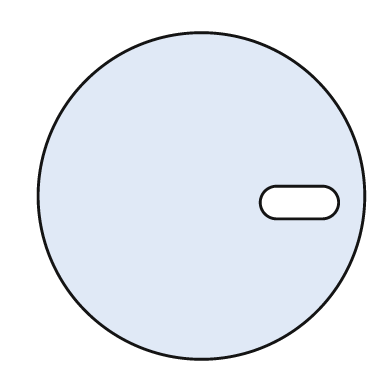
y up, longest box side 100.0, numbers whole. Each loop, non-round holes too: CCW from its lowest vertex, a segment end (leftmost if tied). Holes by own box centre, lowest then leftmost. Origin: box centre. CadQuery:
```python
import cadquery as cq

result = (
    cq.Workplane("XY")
    .moveTo(0.0, 0.0)
    .circle(50.0)
    .moveTo(23.0, -7.0)
    .lineTo(37.0, -7.0)
    .threePointArc((42.0, -2.0), (37.0, 3.0))
    .lineTo(23.0, 3.0)
    .threePointArc((18.0, -2.0), (23.0, -7.0))
    .close()
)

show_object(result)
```